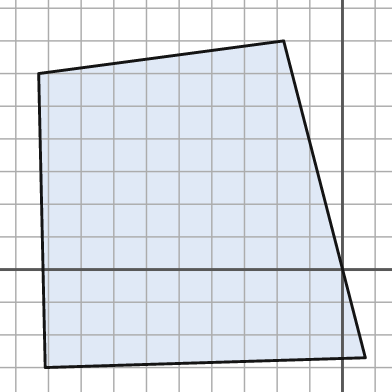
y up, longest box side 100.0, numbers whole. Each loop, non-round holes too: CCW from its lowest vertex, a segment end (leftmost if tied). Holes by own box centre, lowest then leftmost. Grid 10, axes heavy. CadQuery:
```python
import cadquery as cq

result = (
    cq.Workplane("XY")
    .moveTo(-91.0, -30.0)
    .lineTo(7.0, -27.0)
    .lineTo(-18.0, 70.0)
    .lineTo(-93.0, 60.0)
    .close()
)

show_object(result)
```